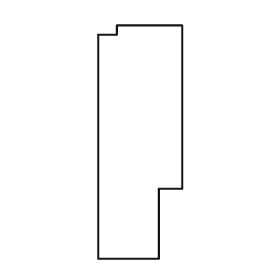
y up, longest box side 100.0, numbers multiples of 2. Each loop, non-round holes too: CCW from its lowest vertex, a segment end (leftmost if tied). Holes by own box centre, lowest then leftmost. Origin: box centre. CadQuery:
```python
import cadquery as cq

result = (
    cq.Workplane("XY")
    .moveTo(-18.0, -50.0)
    .lineTo(8.0, -50.0)
    .lineTo(8.0, -20.0)
    .lineTo(18.0, -20.0)
    .lineTo(18.0, 50.0)
    .lineTo(-10.0, 50.0)
    .lineTo(-10.0, 46.0)
    .lineTo(-18.0, 46.0)
    .close()
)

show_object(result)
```